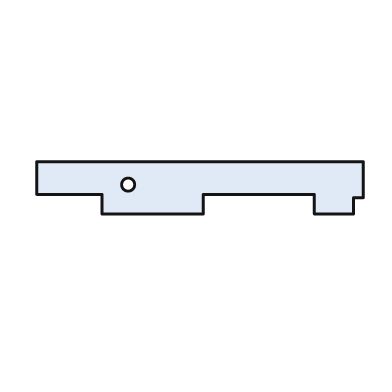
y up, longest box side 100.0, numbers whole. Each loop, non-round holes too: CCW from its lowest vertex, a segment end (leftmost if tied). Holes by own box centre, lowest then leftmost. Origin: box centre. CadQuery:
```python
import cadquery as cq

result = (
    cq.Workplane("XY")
    .moveTo(-30.0, -8.0)
    .lineTo(1.0, -8.0)
    .lineTo(1.0, -2.0)
    .lineTo(35.0, -2.0)
    .lineTo(35.0, -8.0)
    .lineTo(47.0, -8.0)
    .lineTo(47.0, -3.0)
    .lineTo(50.0, -3.0)
    .lineTo(50.0, 8.0)
    .lineTo(-50.0, 8.0)
    .lineTo(-50.0, -2.0)
    .lineTo(-30.0, -2.0)
    .close()
    .moveTo(-22.0, 1.0)
    .circle(2.0)
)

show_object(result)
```